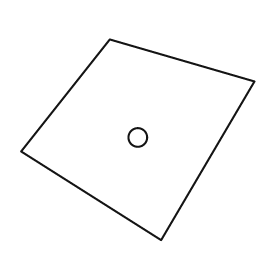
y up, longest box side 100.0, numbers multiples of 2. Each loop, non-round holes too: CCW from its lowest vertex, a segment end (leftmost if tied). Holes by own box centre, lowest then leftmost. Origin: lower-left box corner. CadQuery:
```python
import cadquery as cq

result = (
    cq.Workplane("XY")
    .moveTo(60.0, 0.0)
    .lineTo(100.0, 68.0)
    .lineTo(38.0, 86.0)
    .lineTo(0.0, 38.0)
    .close()
    .moveTo(50.0, 44.0)
    .circle(4.0)
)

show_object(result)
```